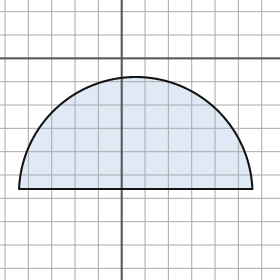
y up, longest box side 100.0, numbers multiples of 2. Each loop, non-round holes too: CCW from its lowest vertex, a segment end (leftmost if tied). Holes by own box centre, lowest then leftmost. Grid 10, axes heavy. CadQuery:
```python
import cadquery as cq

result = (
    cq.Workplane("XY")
    .moveTo(-44.0, -56.0)
    .lineTo(56.0, -56.0)
    .threePointArc((6.0, -8.0), (-44.0, -56.0))
    .close()
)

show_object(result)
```